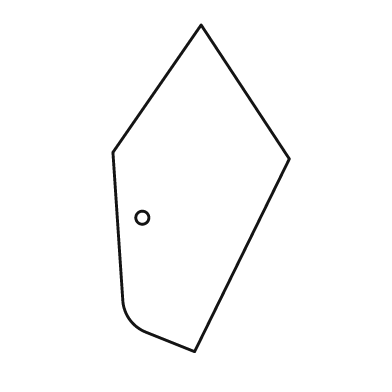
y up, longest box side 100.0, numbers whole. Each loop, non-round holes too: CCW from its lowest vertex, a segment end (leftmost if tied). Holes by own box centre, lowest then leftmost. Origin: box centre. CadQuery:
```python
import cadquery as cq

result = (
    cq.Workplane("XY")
    .moveTo(-2.0, -50.0)
    .lineTo(27.0, 9.0)
    .lineTo(0.0, 50.0)
    .lineTo(-27.0, 11.0)
    .lineTo(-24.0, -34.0)
    .threePointArc((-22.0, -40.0), (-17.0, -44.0))
    .close()
    .moveTo(-18.0, -9.0)
    .circle(2.0)
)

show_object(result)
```